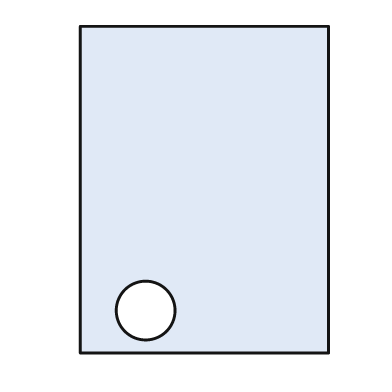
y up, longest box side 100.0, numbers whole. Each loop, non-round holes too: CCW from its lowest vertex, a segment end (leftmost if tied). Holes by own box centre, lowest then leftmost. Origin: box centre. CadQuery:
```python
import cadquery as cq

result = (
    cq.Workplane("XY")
    .moveTo(-38.0, -50.0)
    .lineTo(38.0, -50.0)
    .lineTo(38.0, 50.0)
    .lineTo(-38.0, 50.0)
    .close()
    .moveTo(-18.0, -37.0)
    .circle(9.0)
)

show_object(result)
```